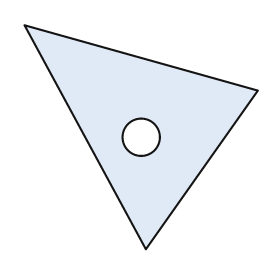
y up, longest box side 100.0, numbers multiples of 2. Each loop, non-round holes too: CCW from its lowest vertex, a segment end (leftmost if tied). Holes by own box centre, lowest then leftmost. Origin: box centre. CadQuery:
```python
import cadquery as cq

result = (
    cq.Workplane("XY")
    .moveTo(2.0, -48.0)
    .lineTo(50.0, 20.0)
    .lineTo(-50.0, 48.0)
    .close()
    .moveTo(0.0, 0.0)
    .circle(8.0)
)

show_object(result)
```